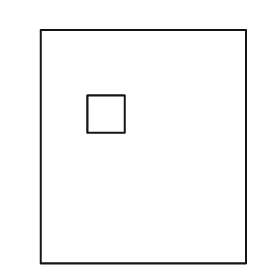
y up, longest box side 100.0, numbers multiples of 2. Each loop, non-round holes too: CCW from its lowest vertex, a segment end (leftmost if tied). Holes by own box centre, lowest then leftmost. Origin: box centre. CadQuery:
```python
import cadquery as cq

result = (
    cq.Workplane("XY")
    .moveTo(-44.0, -50.0)
    .lineTo(44.0, -50.0)
    .lineTo(44.0, 50.0)
    .lineTo(-44.0, 50.0)
    .close()
    .moveTo(-24.0, 6.0)
    .lineTo(-8.0, 6.0)
    .lineTo(-8.0, 22.0)
    .lineTo(-24.0, 22.0)
    .close()
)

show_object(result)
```